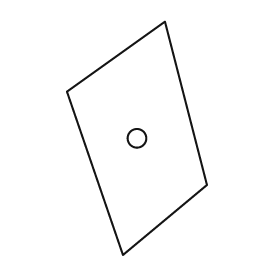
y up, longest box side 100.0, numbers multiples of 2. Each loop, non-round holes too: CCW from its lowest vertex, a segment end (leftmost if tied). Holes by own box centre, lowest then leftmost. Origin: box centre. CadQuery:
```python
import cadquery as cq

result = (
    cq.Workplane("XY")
    .moveTo(-6.0, -50.0)
    .lineTo(30.0, -20.0)
    .lineTo(12.0, 50.0)
    .lineTo(-30.0, 20.0)
    .close()
    .moveTo(0.0, 0.0)
    .circle(4.0)
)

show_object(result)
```